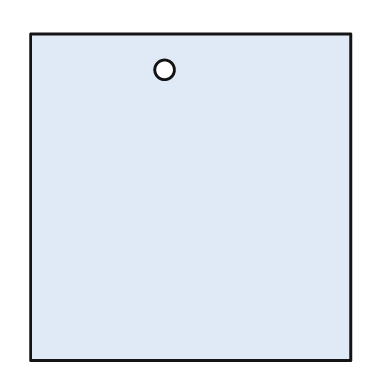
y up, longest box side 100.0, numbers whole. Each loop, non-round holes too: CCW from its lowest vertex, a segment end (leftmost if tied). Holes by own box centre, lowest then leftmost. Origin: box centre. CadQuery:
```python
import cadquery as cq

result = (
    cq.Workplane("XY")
    .moveTo(-49.0, -50.0)
    .lineTo(49.0, -50.0)
    .lineTo(49.0, 50.0)
    .lineTo(-49.0, 50.0)
    .close()
    .moveTo(-8.0, 39.0)
    .circle(3.0)
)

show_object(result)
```